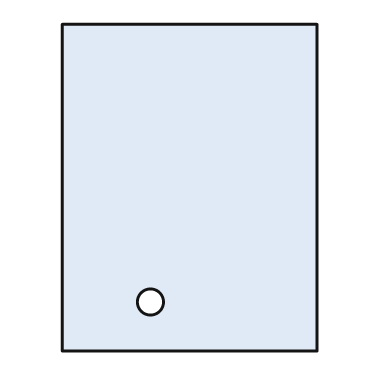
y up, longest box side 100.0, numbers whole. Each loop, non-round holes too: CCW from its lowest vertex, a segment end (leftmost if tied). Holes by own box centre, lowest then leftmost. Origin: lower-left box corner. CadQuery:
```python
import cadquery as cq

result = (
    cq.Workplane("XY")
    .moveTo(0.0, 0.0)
    .lineTo(78.0, 0.0)
    .lineTo(78.0, 100.0)
    .lineTo(0.0, 100.0)
    .close()
    .moveTo(27.0, 15.0)
    .circle(4.0)
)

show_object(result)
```